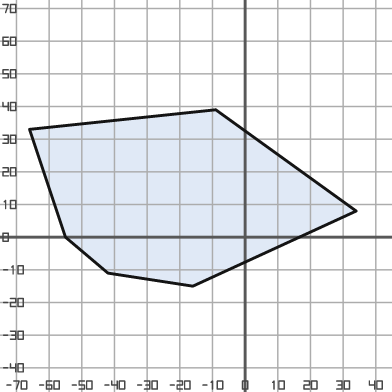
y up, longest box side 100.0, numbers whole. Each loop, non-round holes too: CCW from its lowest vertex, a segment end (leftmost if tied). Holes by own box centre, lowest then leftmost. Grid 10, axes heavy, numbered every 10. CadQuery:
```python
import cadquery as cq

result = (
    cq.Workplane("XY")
    .moveTo(-16.0, -15.0)
    .lineTo(34.0, 8.0)
    .lineTo(-9.0, 39.0)
    .lineTo(-66.0, 33.0)
    .lineTo(-55.0, 0.0)
    .lineTo(-42.0, -11.0)
    .close()
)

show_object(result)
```